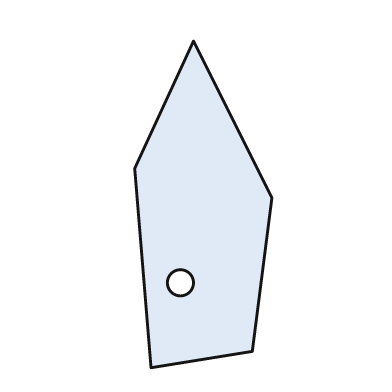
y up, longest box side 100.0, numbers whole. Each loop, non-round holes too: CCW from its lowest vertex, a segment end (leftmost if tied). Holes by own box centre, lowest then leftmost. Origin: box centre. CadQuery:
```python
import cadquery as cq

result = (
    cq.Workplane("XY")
    .moveTo(-16.0, -50.0)
    .lineTo(15.0, -45.0)
    .lineTo(21.0, 2.0)
    .lineTo(-3.0, 50.0)
    .lineTo(-21.0, 11.0)
    .close()
    .moveTo(-7.0, -24.0)
    .circle(4.0)
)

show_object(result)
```